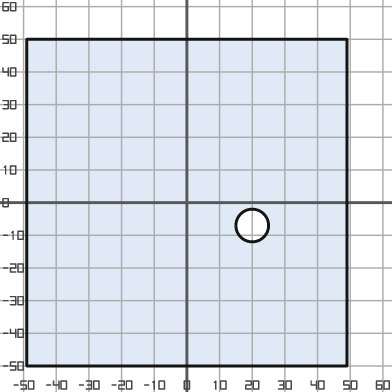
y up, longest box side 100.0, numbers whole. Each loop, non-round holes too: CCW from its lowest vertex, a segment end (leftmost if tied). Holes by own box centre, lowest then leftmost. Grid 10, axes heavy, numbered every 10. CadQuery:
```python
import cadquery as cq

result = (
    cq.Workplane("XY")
    .moveTo(-49.0, -50.0)
    .lineTo(49.0, -50.0)
    .lineTo(49.0, 50.0)
    .lineTo(-49.0, 50.0)
    .close()
    .moveTo(20.0, -7.0)
    .circle(5.0)
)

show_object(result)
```